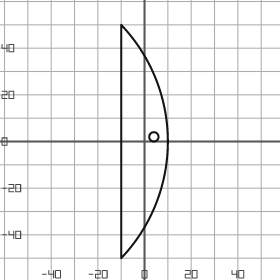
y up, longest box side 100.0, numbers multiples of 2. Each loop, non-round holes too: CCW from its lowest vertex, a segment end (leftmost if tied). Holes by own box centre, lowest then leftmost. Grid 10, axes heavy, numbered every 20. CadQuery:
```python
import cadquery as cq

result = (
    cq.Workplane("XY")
    .moveTo(-10.0, -50.0)
    .threePointArc((10.0, 0.0), (-10.0, 50.0))
    .close()
    .moveTo(4.0, 2.0)
    .circle(2.0)
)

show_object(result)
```